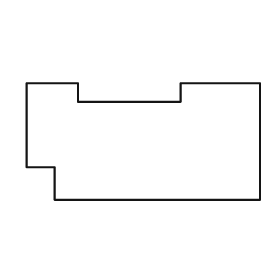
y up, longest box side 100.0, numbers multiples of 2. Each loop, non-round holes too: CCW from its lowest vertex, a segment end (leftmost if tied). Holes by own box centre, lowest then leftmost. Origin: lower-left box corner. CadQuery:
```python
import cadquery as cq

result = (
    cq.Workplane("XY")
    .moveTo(12.0, 0.0)
    .lineTo(100.0, 0.0)
    .lineTo(100.0, 50.0)
    .lineTo(66.0, 50.0)
    .lineTo(66.0, 42.0)
    .lineTo(22.0, 42.0)
    .lineTo(22.0, 50.0)
    .lineTo(0.0, 50.0)
    .lineTo(0.0, 14.0)
    .lineTo(12.0, 14.0)
    .close()
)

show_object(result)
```